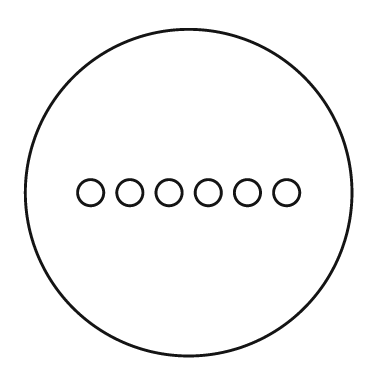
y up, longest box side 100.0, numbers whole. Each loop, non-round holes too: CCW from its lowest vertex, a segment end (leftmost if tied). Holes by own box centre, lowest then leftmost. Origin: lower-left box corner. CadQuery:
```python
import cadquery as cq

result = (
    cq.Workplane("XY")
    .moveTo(50.0, 50.0)
    .circle(50.0)
    .moveTo(20.0, 50.0)
    .circle(4.0)
    .moveTo(32.0, 50.0)
    .circle(4.0)
    .moveTo(44.0, 50.0)
    .circle(4.0)
    .moveTo(56.0, 50.0)
    .circle(4.0)
    .moveTo(68.0, 50.0)
    .circle(4.0)
    .moveTo(80.0, 50.0)
    .circle(4.0)
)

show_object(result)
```